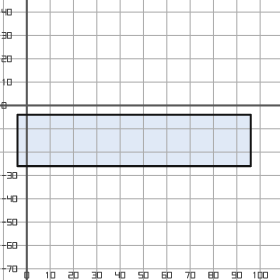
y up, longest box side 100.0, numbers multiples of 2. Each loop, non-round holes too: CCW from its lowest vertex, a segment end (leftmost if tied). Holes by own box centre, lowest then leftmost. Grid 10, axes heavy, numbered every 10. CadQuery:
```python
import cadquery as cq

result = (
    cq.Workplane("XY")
    .moveTo(-4.0, -26.0)
    .lineTo(96.0, -26.0)
    .lineTo(96.0, -4.0)
    .lineTo(-4.0, -4.0)
    .close()
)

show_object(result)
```